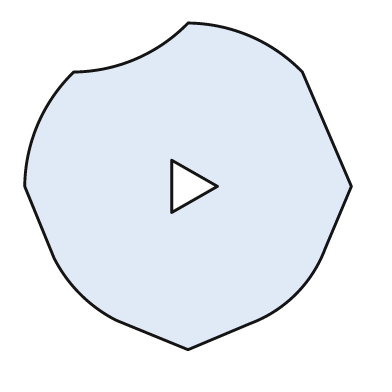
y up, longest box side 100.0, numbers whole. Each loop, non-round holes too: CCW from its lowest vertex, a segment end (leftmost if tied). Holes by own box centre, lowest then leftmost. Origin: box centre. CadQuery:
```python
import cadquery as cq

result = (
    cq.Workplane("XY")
    .moveTo(0.0, -50.0)
    .lineTo(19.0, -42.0)
    .threePointArc((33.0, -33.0), (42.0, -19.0))
    .lineTo(50.0, 0.0)
    .lineTo(35.0, 35.0)
    .threePointArc((19.0, 46.0), (0.0, 50.0))
    .threePointArc((-16.0, 39.0), (-35.0, 35.0))
    .threePointArc((-46.0, 19.0), (-50.0, 0.0))
    .lineTo(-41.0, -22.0)
    .threePointArc((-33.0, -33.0), (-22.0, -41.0))
    .close()
    .moveTo(-5.0, -8.0)
    .lineTo(9.0, 0.0)
    .lineTo(-5.0, 8.0)
    .close()
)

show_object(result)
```